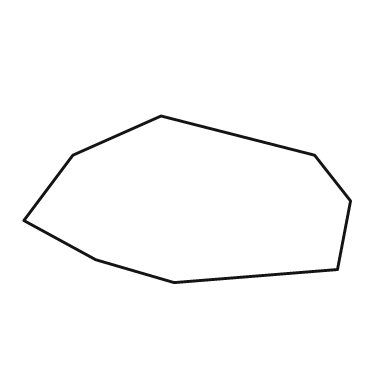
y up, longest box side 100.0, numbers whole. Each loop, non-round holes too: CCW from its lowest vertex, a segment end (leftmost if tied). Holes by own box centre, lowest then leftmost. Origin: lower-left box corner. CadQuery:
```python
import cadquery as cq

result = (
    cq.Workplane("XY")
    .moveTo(46.0, 0.0)
    .lineTo(96.0, 4.0)
    .lineTo(100.0, 25.0)
    .lineTo(89.0, 39.0)
    .lineTo(42.0, 51.0)
    .lineTo(15.0, 39.0)
    .lineTo(0.0, 19.0)
    .lineTo(22.0, 7.0)
    .close()
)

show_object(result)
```